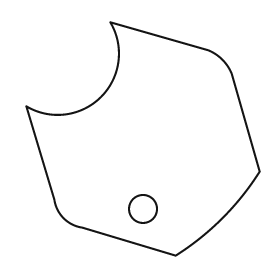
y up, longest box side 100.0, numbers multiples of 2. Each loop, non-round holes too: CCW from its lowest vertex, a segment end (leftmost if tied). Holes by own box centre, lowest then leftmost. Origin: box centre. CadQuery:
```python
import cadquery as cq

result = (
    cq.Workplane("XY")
    .moveTo(14.0, -50.0)
    .threePointArc((34.0, -34.0), (50.0, -14.0))
    .lineTo(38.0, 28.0)
    .threePointArc((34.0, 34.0), (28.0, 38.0))
    .lineTo(-14.0, 50.0)
    .threePointArc((-18.0, 18.0), (-50.0, 14.0))
    .lineTo(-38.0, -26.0)
    .threePointArc((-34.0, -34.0), (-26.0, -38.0))
    .close()
    .moveTo(0.0, -30.0)
    .circle(6.0)
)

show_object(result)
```